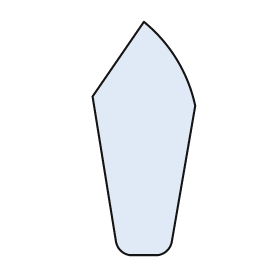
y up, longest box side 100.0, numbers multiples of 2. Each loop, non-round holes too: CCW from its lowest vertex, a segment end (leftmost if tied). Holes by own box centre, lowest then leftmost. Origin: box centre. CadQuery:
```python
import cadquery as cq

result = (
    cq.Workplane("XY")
    .moveTo(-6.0, -50.0)
    .lineTo(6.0, -50.0)
    .threePointArc((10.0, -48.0), (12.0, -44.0))
    .lineTo(22.0, 14.0)
    .threePointArc((14.0, 34.0), (0.0, 50.0))
    .lineTo(-22.0, 18.0)
    .lineTo(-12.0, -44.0)
    .threePointArc((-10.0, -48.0), (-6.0, -50.0))
    .close()
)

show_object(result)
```